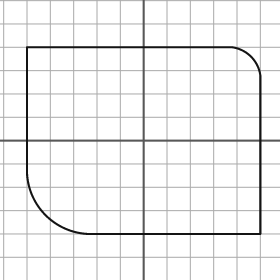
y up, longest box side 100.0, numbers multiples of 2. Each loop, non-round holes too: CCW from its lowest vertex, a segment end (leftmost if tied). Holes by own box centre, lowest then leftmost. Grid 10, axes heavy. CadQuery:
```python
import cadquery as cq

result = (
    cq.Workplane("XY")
    .moveTo(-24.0, -40.0)
    .lineTo(50.0, -40.0)
    .lineTo(50.0, 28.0)
    .threePointArc((46.0, 36.0), (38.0, 40.0))
    .lineTo(-50.0, 40.0)
    .lineTo(-50.0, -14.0)
    .threePointArc((-42.0, -32.0), (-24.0, -40.0))
    .close()
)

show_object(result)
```